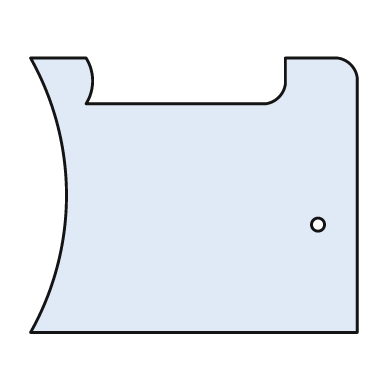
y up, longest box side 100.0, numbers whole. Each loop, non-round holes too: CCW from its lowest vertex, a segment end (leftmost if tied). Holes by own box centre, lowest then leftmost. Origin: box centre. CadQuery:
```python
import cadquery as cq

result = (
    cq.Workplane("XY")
    .moveTo(-50.0, -42.0)
    .lineTo(50.0, -42.0)
    .lineTo(50.0, 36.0)
    .threePointArc((48.0, 40.0), (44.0, 42.0))
    .lineTo(28.0, 42.0)
    .lineTo(28.0, 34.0)
    .threePointArc((26.0, 30.0), (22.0, 28.0))
    .lineTo(-33.0, 28.0)
    .threePointArc((-31.0, 35.0), (-33.0, 42.0))
    .lineTo(-50.0, 42.0)
    .threePointArc((-39.0, 0.0), (-50.0, -42.0))
    .close()
    .moveTo(38.0, -9.0)
    .circle(2.0)
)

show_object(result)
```